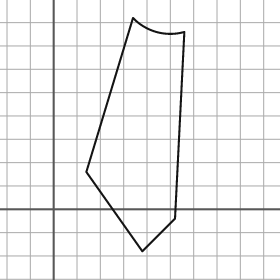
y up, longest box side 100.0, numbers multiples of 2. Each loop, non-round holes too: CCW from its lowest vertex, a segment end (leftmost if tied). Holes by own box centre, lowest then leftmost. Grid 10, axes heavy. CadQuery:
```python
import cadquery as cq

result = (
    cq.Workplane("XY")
    .moveTo(38.0, -18.0)
    .lineTo(52.0, -4.0)
    .lineTo(56.0, 76.0)
    .threePointArc((44.0, 76.0), (34.0, 82.0))
    .lineTo(14.0, 16.0)
    .close()
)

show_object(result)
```